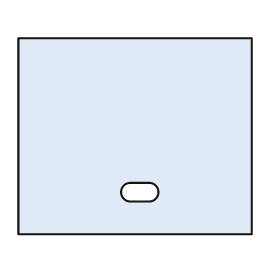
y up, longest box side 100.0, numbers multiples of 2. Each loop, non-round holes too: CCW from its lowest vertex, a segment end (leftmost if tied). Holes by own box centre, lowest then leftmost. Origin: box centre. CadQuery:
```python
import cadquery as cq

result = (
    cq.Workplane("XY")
    .moveTo(-50.0, -42.0)
    .lineTo(50.0, -42.0)
    .lineTo(50.0, 42.0)
    .lineTo(-50.0, 42.0)
    .close()
    .moveTo(-2.0, -28.0)
    .lineTo(6.0, -28.0)
    .threePointArc((10.0, -24.0), (6.0, -20.0))
    .lineTo(-2.0, -20.0)
    .threePointArc((-6.0, -24.0), (-2.0, -28.0))
    .close()
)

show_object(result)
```